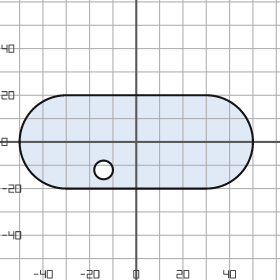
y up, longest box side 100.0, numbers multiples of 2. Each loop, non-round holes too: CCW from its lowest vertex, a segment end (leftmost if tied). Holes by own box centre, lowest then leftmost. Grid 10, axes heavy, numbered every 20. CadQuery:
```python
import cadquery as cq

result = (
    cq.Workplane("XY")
    .moveTo(-30.0, -20.0)
    .lineTo(30.0, -20.0)
    .threePointArc((50.0, 0.0), (30.0, 20.0))
    .lineTo(-30.0, 20.0)
    .threePointArc((-50.0, 0.0), (-30.0, -20.0))
    .close()
    .moveTo(-14.0, -12.0)
    .circle(4.0)
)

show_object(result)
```